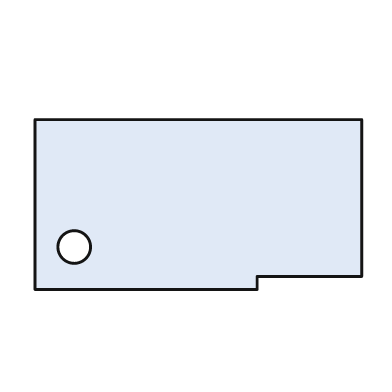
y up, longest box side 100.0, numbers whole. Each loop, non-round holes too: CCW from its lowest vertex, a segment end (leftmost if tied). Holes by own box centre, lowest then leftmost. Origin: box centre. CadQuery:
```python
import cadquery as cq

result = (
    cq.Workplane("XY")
    .moveTo(-50.0, -26.0)
    .lineTo(18.0, -26.0)
    .lineTo(18.0, -22.0)
    .lineTo(50.0, -22.0)
    .lineTo(50.0, 26.0)
    .lineTo(-50.0, 26.0)
    .close()
    .moveTo(-38.0, -13.0)
    .circle(5.0)
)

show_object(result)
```